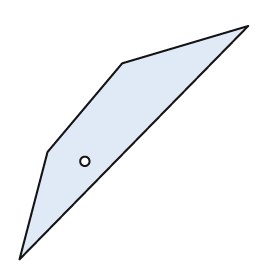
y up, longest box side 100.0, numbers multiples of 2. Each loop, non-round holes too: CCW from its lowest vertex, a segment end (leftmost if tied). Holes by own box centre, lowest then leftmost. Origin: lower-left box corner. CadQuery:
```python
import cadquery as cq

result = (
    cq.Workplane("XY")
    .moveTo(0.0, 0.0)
    .lineTo(98.0, 100.0)
    .lineTo(44.0, 84.0)
    .lineTo(12.0, 46.0)
    .close()
    .moveTo(28.0, 42.0)
    .circle(2.0)
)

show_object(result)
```